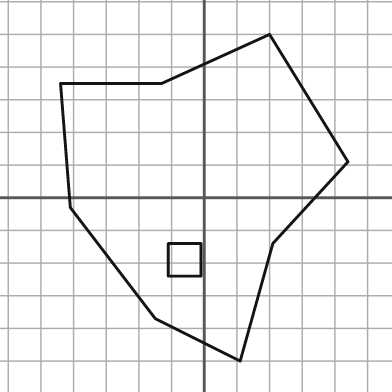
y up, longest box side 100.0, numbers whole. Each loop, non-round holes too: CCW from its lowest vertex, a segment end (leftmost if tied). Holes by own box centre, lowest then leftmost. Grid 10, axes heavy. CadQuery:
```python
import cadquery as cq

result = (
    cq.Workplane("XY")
    .moveTo(11.0, -50.0)
    .lineTo(21.0, -14.0)
    .lineTo(44.0, 11.0)
    .lineTo(20.0, 50.0)
    .lineTo(-13.0, 35.0)
    .lineTo(-44.0, 35.0)
    .lineTo(-41.0, -3.0)
    .lineTo(-15.0, -37.0)
    .close()
    .moveTo(-11.0, -24.0)
    .lineTo(-1.0, -24.0)
    .lineTo(-1.0, -14.0)
    .lineTo(-11.0, -14.0)
    .close()
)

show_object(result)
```